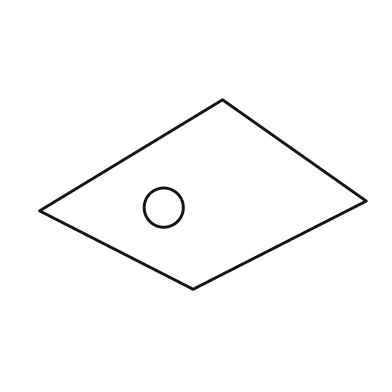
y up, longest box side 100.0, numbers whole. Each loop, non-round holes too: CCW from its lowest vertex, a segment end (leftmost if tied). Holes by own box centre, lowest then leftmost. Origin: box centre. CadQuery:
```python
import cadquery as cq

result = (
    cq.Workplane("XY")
    .moveTo(-3.0, -29.0)
    .lineTo(50.0, -2.0)
    .lineTo(6.0, 29.0)
    .lineTo(-50.0, -5.0)
    .close()
    .moveTo(-12.0, -4.0)
    .circle(6.0)
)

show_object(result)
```